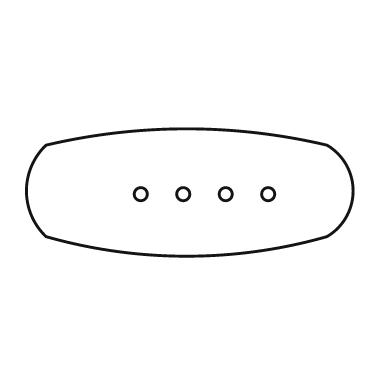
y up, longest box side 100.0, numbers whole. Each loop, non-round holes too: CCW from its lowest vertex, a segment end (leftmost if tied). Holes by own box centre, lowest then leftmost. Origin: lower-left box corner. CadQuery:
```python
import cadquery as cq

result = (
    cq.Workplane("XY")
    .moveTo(6.0, 6.0)
    .threePointArc((49.0, 0.0), (92.0, 6.0))
    .threePointArc((100.0, 20.0), (92.0, 34.0))
    .threePointArc((49.0, 39.0), (6.0, 34.0))
    .threePointArc((0.0, 20.0), (6.0, 6.0))
    .close()
    .moveTo(35.0, 19.0)
    .circle(2.0)
    .moveTo(48.0, 19.0)
    .circle(2.0)
    .moveTo(61.0, 19.0)
    .circle(2.0)
    .moveTo(74.0, 19.0)
    .circle(2.0)
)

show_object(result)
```